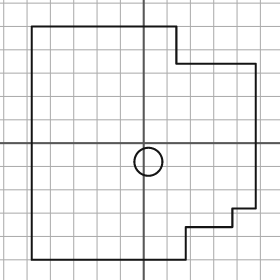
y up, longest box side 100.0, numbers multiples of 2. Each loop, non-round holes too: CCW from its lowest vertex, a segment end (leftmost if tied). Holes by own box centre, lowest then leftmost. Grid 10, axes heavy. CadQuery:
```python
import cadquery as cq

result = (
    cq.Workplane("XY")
    .moveTo(-48.0, -50.0)
    .lineTo(18.0, -50.0)
    .lineTo(18.0, -36.0)
    .lineTo(38.0, -36.0)
    .lineTo(38.0, -28.0)
    .lineTo(48.0, -28.0)
    .lineTo(48.0, 34.0)
    .lineTo(14.0, 34.0)
    .lineTo(14.0, 50.0)
    .lineTo(-48.0, 50.0)
    .close()
    .moveTo(2.0, -8.0)
    .circle(6.0)
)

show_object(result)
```